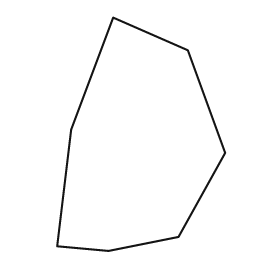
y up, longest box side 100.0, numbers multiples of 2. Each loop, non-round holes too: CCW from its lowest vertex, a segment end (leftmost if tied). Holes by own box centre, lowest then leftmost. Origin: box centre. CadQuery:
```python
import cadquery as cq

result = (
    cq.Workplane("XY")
    .moveTo(-14.0, -50.0)
    .lineTo(16.0, -44.0)
    .lineTo(36.0, -8.0)
    .lineTo(20.0, 36.0)
    .lineTo(-12.0, 50.0)
    .lineTo(-30.0, 2.0)
    .lineTo(-36.0, -48.0)
    .close()
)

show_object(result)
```